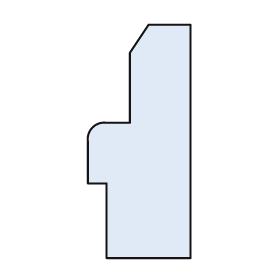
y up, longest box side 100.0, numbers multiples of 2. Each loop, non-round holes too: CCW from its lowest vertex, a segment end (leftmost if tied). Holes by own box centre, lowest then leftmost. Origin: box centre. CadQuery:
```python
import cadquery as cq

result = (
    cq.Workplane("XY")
    .moveTo(-14.0, -50.0)
    .lineTo(22.0, -50.0)
    .lineTo(22.0, 50.0)
    .lineTo(4.0, 50.0)
    .lineTo(-4.0, 38.0)
    .lineTo(-4.0, 8.0)
    .lineTo(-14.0, 8.0)
    .threePointArc((-20.0, 6.0), (-22.0, 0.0))
    .lineTo(-22.0, -18.0)
    .lineTo(-14.0, -18.0)
    .close()
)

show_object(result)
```